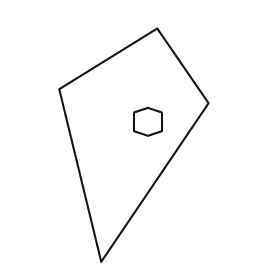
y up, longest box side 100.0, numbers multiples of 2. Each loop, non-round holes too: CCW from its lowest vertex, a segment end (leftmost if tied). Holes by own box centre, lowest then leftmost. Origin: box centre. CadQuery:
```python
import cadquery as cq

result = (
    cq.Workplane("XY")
    .moveTo(-14.0, -50.0)
    .lineTo(32.0, 18.0)
    .lineTo(10.0, 50.0)
    .lineTo(-32.0, 24.0)
    .close()
    .moveTo(6.0, 4.0)
    .lineTo(12.0, 6.0)
    .lineTo(12.0, 14.0)
    .lineTo(6.0, 16.0)
    .lineTo(0.0, 14.0)
    .lineTo(0.0, 6.0)
    .close()
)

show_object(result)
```